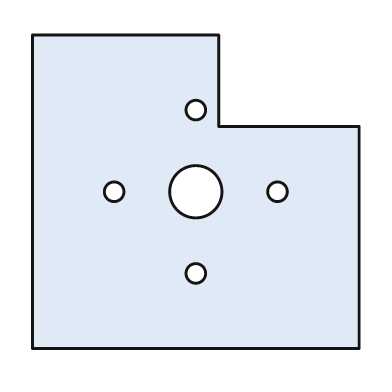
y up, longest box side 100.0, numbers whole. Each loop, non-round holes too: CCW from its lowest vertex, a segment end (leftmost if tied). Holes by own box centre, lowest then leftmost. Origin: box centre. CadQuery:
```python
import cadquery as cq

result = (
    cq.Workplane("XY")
    .moveTo(-50.0, -48.0)
    .lineTo(50.0, -48.0)
    .lineTo(50.0, 20.0)
    .lineTo(7.0, 20.0)
    .lineTo(7.0, 48.0)
    .lineTo(-50.0, 48.0)
    .close()
    .moveTo(0.0, -25.0)
    .circle(3.0)
    .moveTo(-25.0, 0.0)
    .circle(3.0)
    .moveTo(0.0, 0.0)
    .circle(8.0)
    .moveTo(25.0, 0.0)
    .circle(3.0)
    .moveTo(0.0, 25.0)
    .circle(3.0)
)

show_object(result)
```